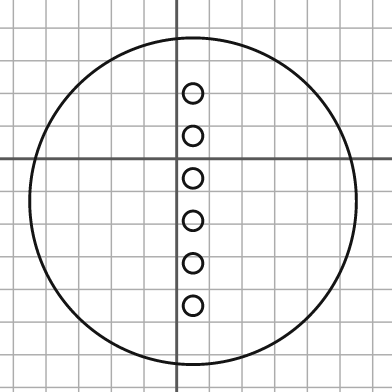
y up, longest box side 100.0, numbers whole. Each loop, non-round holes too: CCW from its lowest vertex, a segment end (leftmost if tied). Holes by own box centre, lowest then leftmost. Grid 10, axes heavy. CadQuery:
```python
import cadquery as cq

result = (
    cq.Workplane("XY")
    .moveTo(5.0, -13.0)
    .circle(50.0)
    .moveTo(5.0, -45.0)
    .circle(3.0)
    .moveTo(5.0, -32.0)
    .circle(3.0)
    .moveTo(5.0, -19.0)
    .circle(3.0)
    .moveTo(5.0, -6.0)
    .circle(3.0)
    .moveTo(5.0, 7.0)
    .circle(3.0)
    .moveTo(5.0, 20.0)
    .circle(3.0)
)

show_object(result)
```